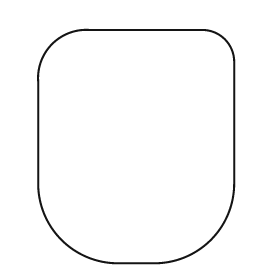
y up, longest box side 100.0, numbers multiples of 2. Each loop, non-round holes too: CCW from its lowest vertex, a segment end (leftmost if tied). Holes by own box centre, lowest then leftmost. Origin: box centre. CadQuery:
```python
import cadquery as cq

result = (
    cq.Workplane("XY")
    .moveTo(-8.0, -50.0)
    .lineTo(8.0, -50.0)
    .threePointArc((32.0, -40.0), (42.0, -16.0))
    .lineTo(42.0, 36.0)
    .threePointArc((38.0, 46.0), (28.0, 50.0))
    .lineTo(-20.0, 50.0)
    .threePointArc((-36.0, 44.0), (-42.0, 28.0))
    .lineTo(-42.0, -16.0)
    .threePointArc((-32.0, -40.0), (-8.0, -50.0))
    .close()
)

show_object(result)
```